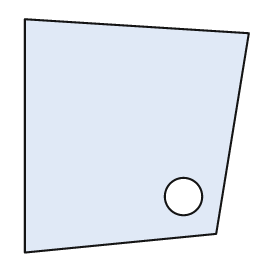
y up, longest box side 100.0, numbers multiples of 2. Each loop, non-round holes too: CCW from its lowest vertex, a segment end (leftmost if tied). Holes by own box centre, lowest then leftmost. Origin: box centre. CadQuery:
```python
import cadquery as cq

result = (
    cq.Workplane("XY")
    .moveTo(-48.0, -50.0)
    .lineTo(34.0, -42.0)
    .lineTo(48.0, 44.0)
    .lineTo(-48.0, 50.0)
    .close()
    .moveTo(20.0, -26.0)
    .circle(8.0)
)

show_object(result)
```